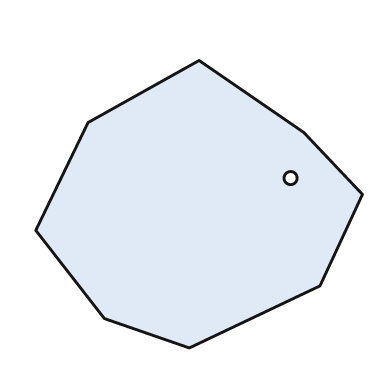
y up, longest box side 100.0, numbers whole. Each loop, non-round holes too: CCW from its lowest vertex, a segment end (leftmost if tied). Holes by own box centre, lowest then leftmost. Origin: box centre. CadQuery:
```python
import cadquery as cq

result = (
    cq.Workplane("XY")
    .moveTo(-3.0, -44.0)
    .lineTo(37.0, -25.0)
    .lineTo(50.0, 3.0)
    .lineTo(32.0, 22.0)
    .lineTo(0.0, 44.0)
    .lineTo(-34.0, 25.0)
    .lineTo(-50.0, -8.0)
    .lineTo(-29.0, -35.0)
    .close()
    .moveTo(28.0, 8.0)
    .circle(2.0)
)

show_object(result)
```